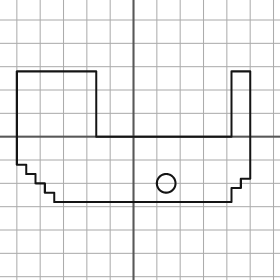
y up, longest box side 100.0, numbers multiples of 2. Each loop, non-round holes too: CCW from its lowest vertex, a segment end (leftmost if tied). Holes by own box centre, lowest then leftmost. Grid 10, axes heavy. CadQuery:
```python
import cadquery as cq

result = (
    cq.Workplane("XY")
    .moveTo(-34.0, -28.0)
    .lineTo(42.0, -28.0)
    .lineTo(42.0, -22.0)
    .lineTo(46.0, -22.0)
    .lineTo(46.0, -18.0)
    .lineTo(50.0, -18.0)
    .lineTo(50.0, 28.0)
    .lineTo(42.0, 28.0)
    .lineTo(42.0, 0.0)
    .lineTo(-16.0, 0.0)
    .lineTo(-16.0, 28.0)
    .lineTo(-50.0, 28.0)
    .lineTo(-50.0, -12.0)
    .lineTo(-46.0, -12.0)
    .lineTo(-46.0, -16.0)
    .lineTo(-42.0, -16.0)
    .lineTo(-42.0, -20.0)
    .lineTo(-38.0, -20.0)
    .lineTo(-38.0, -24.0)
    .lineTo(-34.0, -24.0)
    .close()
    .moveTo(14.0, -20.0)
    .circle(4.0)
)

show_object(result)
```